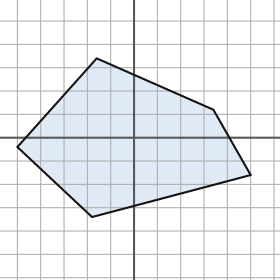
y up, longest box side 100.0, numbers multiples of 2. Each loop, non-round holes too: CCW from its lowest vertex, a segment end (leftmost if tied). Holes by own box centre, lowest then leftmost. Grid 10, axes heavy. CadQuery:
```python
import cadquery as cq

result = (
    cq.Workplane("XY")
    .moveTo(-18.0, -34.0)
    .lineTo(50.0, -16.0)
    .lineTo(34.0, 12.0)
    .lineTo(-16.0, 34.0)
    .lineTo(-50.0, -4.0)
    .close()
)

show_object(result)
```